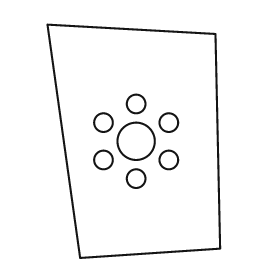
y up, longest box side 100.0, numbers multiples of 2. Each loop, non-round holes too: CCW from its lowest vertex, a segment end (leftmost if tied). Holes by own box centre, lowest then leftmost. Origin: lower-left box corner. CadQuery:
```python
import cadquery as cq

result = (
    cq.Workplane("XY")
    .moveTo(14.0, 0.0)
    .lineTo(74.0, 4.0)
    .lineTo(72.0, 96.0)
    .lineTo(0.0, 100.0)
    .close()
    .moveTo(38.0, 34.0)
    .circle(4.0)
    .moveTo(24.0, 42.0)
    .circle(4.0)
    .moveTo(52.0, 42.0)
    .circle(4.0)
    .moveTo(38.0, 50.0)
    .circle(8.0)
    .moveTo(24.0, 58.0)
    .circle(4.0)
    .moveTo(52.0, 58.0)
    .circle(4.0)
    .moveTo(38.0, 66.0)
    .circle(4.0)
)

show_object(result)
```